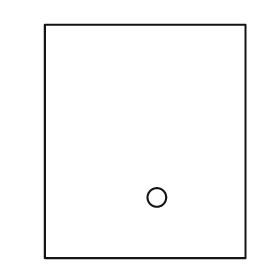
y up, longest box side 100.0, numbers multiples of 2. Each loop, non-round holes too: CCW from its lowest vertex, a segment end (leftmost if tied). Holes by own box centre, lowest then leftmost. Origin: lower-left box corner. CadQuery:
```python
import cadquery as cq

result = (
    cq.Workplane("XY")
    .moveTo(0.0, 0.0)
    .lineTo(86.0, 0.0)
    .lineTo(86.0, 100.0)
    .lineTo(0.0, 100.0)
    .close()
    .moveTo(48.0, 26.0)
    .circle(4.0)
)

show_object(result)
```